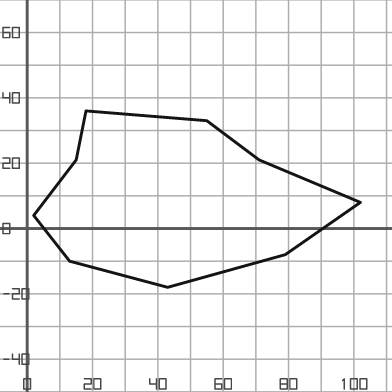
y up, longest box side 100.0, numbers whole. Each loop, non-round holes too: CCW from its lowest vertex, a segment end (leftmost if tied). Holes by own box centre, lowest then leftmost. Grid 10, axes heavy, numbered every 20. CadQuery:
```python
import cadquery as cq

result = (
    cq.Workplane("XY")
    .moveTo(43.0, -18.0)
    .lineTo(79.0, -8.0)
    .lineTo(102.0, 8.0)
    .lineTo(71.0, 21.0)
    .lineTo(55.0, 33.0)
    .lineTo(18.0, 36.0)
    .lineTo(15.0, 21.0)
    .lineTo(2.0, 4.0)
    .lineTo(13.0, -10.0)
    .close()
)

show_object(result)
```